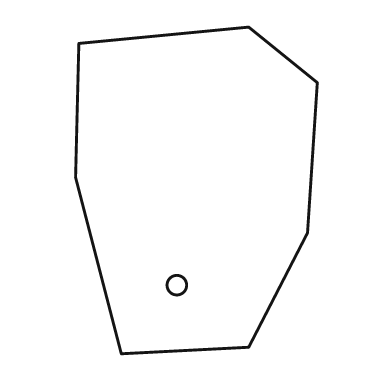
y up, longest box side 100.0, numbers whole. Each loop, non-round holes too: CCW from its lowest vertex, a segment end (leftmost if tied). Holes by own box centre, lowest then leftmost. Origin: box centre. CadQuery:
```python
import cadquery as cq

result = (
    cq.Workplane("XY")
    .moveTo(-23.0, -50.0)
    .lineTo(16.0, -48.0)
    .lineTo(34.0, -13.0)
    .lineTo(37.0, 33.0)
    .lineTo(16.0, 50.0)
    .lineTo(-36.0, 45.0)
    .lineTo(-37.0, 4.0)
    .close()
    .moveTo(-6.0, -29.0)
    .circle(3.0)
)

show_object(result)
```